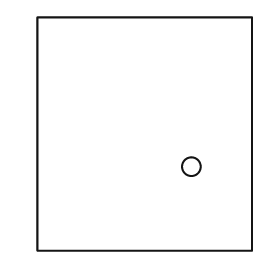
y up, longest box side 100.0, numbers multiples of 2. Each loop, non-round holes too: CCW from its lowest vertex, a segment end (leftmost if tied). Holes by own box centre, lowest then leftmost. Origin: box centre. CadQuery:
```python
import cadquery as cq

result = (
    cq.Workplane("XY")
    .moveTo(-46.0, -50.0)
    .lineTo(46.0, -50.0)
    .lineTo(46.0, 50.0)
    .lineTo(-46.0, 50.0)
    .close()
    .moveTo(20.0, -14.0)
    .circle(4.0)
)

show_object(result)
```